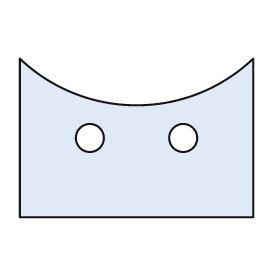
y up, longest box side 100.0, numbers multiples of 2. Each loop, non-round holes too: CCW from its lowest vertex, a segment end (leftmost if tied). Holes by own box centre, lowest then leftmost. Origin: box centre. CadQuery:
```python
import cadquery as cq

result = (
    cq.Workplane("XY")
    .moveTo(-50.0, -34.0)
    .lineTo(50.0, -34.0)
    .lineTo(50.0, 34.0)
    .threePointArc((0.0, 14.0), (-50.0, 34.0))
    .close()
    .moveTo(-20.0, 0.0)
    .circle(6.0)
    .moveTo(20.0, 0.0)
    .circle(6.0)
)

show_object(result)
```